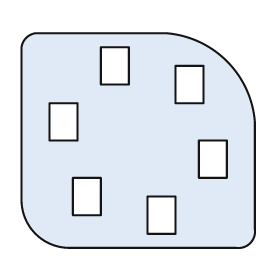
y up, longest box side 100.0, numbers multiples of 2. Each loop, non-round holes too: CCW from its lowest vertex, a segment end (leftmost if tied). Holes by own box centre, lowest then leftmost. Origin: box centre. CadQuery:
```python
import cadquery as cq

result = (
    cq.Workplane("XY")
    .moveTo(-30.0, -46.0)
    .lineTo(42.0, -46.0)
    .threePointArc((48.0, -44.0), (50.0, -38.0))
    .lineTo(50.0, 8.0)
    .threePointArc((38.0, 34.0), (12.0, 46.0))
    .lineTo(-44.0, 46.0)
    .threePointArc((-48.0, 44.0), (-50.0, 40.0))
    .lineTo(-50.0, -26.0)
    .threePointArc((-44.0, -40.0), (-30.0, -46.0))
    .close()
    .moveTo(4.0, -40.0)
    .lineTo(16.0, -40.0)
    .lineTo(16.0, -24.0)
    .lineTo(4.0, -24.0)
    .close()
    .moveTo(-28.0, -32.0)
    .lineTo(-16.0, -32.0)
    .lineTo(-16.0, -16.0)
    .lineTo(-28.0, -16.0)
    .close()
    .moveTo(26.0, -16.0)
    .lineTo(38.0, -16.0)
    .lineTo(38.0, 0.0)
    .lineTo(26.0, 0.0)
    .close()
    .moveTo(-38.0, 0.0)
    .lineTo(-26.0, 0.0)
    .lineTo(-26.0, 16.0)
    .lineTo(-38.0, 16.0)
    .close()
    .moveTo(16.0, 16.0)
    .lineTo(28.0, 16.0)
    .lineTo(28.0, 32.0)
    .lineTo(16.0, 32.0)
    .close()
    .moveTo(-16.0, 24.0)
    .lineTo(-4.0, 24.0)
    .lineTo(-4.0, 40.0)
    .lineTo(-16.0, 40.0)
    .close()
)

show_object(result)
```